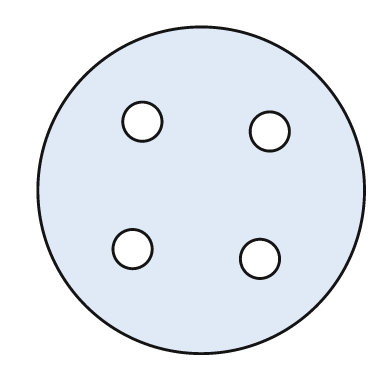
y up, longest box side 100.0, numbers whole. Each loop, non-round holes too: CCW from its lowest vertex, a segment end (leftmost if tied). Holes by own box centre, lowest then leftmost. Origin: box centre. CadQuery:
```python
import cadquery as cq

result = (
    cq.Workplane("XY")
    .moveTo(0.0, 0.0)
    .circle(50.0)
    .moveTo(18.0, -21.0)
    .circle(6.0)
    .moveTo(-21.0, -18.0)
    .circle(6.0)
    .moveTo(21.0, 18.0)
    .circle(6.0)
    .moveTo(-18.0, 21.0)
    .circle(6.0)
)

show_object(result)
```